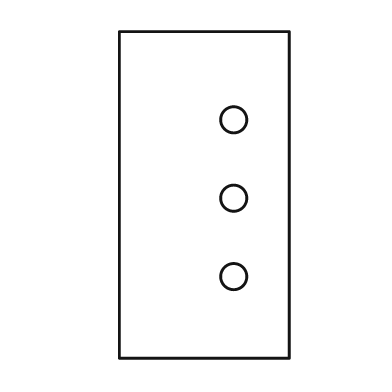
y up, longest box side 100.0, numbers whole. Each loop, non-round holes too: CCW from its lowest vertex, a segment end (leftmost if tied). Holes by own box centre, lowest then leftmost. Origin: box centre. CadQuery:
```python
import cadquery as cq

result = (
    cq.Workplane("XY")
    .moveTo(-26.0, -50.0)
    .lineTo(26.0, -50.0)
    .lineTo(26.0, 50.0)
    .lineTo(-26.0, 50.0)
    .close()
    .moveTo(9.0, -25.0)
    .circle(4.0)
    .moveTo(9.0, -1.0)
    .circle(4.0)
    .moveTo(9.0, 23.0)
    .circle(4.0)
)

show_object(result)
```